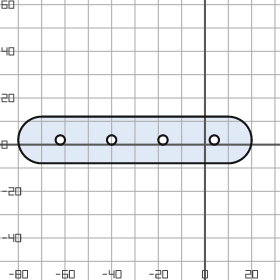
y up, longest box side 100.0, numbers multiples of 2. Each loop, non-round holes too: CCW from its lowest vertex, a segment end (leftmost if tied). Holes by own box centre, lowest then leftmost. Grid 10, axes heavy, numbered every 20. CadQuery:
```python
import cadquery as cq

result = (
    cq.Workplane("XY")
    .moveTo(-70.0, -8.0)
    .lineTo(10.0, -8.0)
    .threePointArc((20.0, 2.0), (10.0, 12.0))
    .lineTo(-70.0, 12.0)
    .threePointArc((-80.0, 2.0), (-70.0, -8.0))
    .close()
    .moveTo(-62.0, 2.0)
    .circle(2.0)
    .moveTo(-40.0, 2.0)
    .circle(2.0)
    .moveTo(-18.0, 2.0)
    .circle(2.0)
    .moveTo(4.0, 2.0)
    .circle(2.0)
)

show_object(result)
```